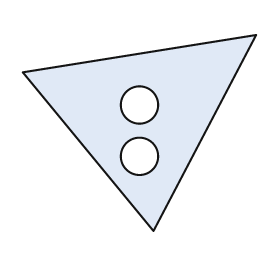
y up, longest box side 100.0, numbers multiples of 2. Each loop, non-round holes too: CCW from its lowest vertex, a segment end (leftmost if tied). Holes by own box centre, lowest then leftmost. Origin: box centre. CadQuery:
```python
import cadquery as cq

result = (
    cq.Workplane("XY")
    .moveTo(6.0, -42.0)
    .lineTo(50.0, 42.0)
    .lineTo(-50.0, 26.0)
    .close()
    .moveTo(0.0, -10.0)
    .circle(8.0)
    .moveTo(0.0, 12.0)
    .circle(8.0)
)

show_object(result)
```